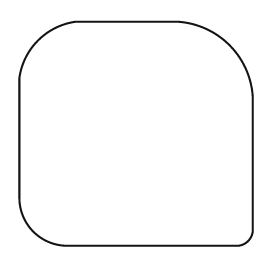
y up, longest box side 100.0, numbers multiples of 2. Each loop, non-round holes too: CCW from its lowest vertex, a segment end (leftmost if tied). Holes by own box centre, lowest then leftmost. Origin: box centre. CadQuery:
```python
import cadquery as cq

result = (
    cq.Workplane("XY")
    .moveTo(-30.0, -48.0)
    .lineTo(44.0, -48.0)
    .threePointArc((48.0, -46.0), (50.0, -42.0))
    .lineTo(50.0, 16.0)
    .threePointArc((40.0, 38.0), (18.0, 48.0))
    .lineTo(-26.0, 48.0)
    .threePointArc((-42.0, 40.0), (-50.0, 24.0))
    .lineTo(-50.0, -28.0)
    .threePointArc((-44.0, -42.0), (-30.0, -48.0))
    .close()
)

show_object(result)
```